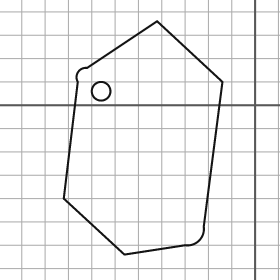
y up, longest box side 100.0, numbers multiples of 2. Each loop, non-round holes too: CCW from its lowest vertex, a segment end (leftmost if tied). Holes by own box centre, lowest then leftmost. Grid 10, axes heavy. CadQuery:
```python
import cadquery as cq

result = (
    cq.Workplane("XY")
    .moveTo(-56.0, -64.0)
    .lineTo(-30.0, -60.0)
    .threePointArc((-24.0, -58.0), (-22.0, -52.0))
    .lineTo(-14.0, 10.0)
    .lineTo(-42.0, 36.0)
    .lineTo(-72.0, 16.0)
    .threePointArc((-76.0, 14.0), (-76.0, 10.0))
    .lineTo(-82.0, -40.0)
    .close()
    .moveTo(-66.0, 6.0)
    .circle(4.0)
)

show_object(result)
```